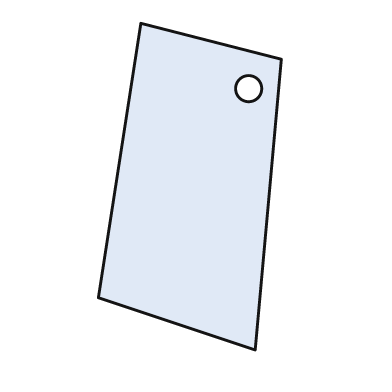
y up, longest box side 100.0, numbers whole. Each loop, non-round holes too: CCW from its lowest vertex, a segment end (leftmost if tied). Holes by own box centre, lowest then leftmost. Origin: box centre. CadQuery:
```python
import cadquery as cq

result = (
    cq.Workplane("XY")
    .moveTo(20.0, -50.0)
    .lineTo(28.0, 39.0)
    .lineTo(-15.0, 50.0)
    .lineTo(-28.0, -34.0)
    .close()
    .moveTo(18.0, 30.0)
    .circle(4.0)
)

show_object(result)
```